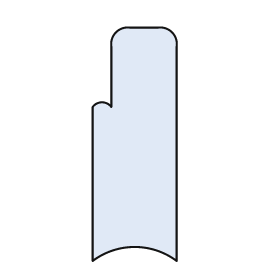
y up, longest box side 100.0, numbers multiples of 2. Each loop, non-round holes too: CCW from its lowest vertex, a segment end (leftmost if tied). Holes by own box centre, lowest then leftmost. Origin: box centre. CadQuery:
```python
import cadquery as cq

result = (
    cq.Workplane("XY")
    .moveTo(-18.0, -50.0)
    .threePointArc((0.0, -44.0), (18.0, -50.0))
    .lineTo(18.0, 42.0)
    .threePointArc((16.0, 48.0), (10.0, 50.0))
    .lineTo(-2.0, 50.0)
    .threePointArc((-8.0, 48.0), (-10.0, 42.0))
    .lineTo(-10.0, 16.0)
    .threePointArc((-14.0, 18.0), (-18.0, 16.0))
    .close()
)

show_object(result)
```